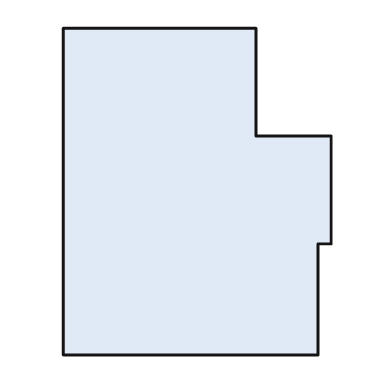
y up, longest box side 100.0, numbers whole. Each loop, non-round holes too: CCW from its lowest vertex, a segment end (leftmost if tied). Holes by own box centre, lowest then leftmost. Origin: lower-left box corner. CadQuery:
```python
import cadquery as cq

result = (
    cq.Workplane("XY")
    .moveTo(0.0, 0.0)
    .lineTo(78.0, 0.0)
    .lineTo(78.0, 34.0)
    .lineTo(82.0, 34.0)
    .lineTo(82.0, 67.0)
    .lineTo(59.0, 67.0)
    .lineTo(59.0, 100.0)
    .lineTo(0.0, 100.0)
    .close()
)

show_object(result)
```